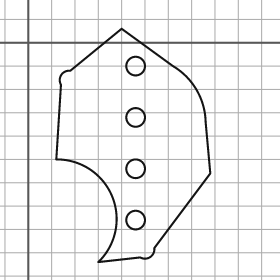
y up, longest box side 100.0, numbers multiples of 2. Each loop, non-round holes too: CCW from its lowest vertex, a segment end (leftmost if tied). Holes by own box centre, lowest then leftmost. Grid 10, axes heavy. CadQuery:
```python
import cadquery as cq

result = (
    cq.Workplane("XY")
    .moveTo(30.0, -94.0)
    .lineTo(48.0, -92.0)
    .threePointArc((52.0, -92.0), (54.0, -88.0))
    .lineTo(78.0, -56.0)
    .lineTo(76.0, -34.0)
    .threePointArc((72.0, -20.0), (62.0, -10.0))
    .lineTo(40.0, 6.0)
    .lineTo(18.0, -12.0)
    .threePointArc((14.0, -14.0), (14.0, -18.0))
    .lineTo(12.0, -50.0)
    .threePointArc((36.0, -66.0), (30.0, -94.0))
    .close()
    .moveTo(46.0, -76.0)
    .circle(4.0)
    .moveTo(46.0, -54.0)
    .circle(4.0)
    .moveTo(46.0, -32.0)
    .circle(4.0)
    .moveTo(46.0, -10.0)
    .circle(4.0)
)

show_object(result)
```